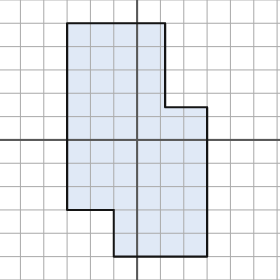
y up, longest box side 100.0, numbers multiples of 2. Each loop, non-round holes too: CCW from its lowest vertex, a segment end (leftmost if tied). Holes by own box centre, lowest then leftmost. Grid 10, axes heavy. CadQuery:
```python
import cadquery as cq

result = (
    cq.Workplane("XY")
    .moveTo(-10.0, -50.0)
    .lineTo(30.0, -50.0)
    .lineTo(30.0, 14.0)
    .lineTo(12.0, 14.0)
    .lineTo(12.0, 50.0)
    .lineTo(-30.0, 50.0)
    .lineTo(-30.0, -30.0)
    .lineTo(-10.0, -30.0)
    .close()
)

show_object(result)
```